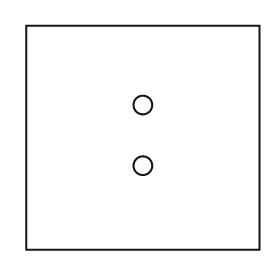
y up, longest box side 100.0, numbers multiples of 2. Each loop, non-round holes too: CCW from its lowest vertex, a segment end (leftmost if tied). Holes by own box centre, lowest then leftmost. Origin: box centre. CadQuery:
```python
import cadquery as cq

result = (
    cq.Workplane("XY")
    .moveTo(-50.0, -48.0)
    .lineTo(50.0, -48.0)
    .lineTo(50.0, 48.0)
    .lineTo(-50.0, 48.0)
    .close()
    .moveTo(0.0, -12.0)
    .circle(4.0)
    .moveTo(0.0, 14.0)
    .circle(4.0)
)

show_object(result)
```